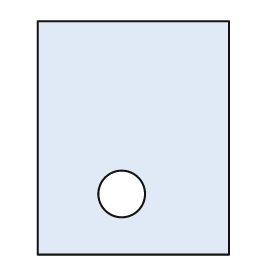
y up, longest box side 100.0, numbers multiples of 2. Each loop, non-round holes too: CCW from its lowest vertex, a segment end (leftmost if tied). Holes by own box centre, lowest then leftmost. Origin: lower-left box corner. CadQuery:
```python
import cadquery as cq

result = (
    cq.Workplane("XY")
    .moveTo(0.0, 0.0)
    .lineTo(82.0, 0.0)
    .lineTo(82.0, 100.0)
    .lineTo(0.0, 100.0)
    .close()
    .moveTo(36.0, 26.0)
    .circle(10.0)
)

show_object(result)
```